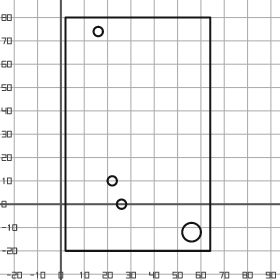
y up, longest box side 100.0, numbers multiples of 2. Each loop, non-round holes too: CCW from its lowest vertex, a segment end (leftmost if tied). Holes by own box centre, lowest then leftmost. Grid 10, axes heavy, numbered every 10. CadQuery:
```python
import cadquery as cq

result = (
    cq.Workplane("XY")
    .moveTo(2.0, -20.0)
    .lineTo(64.0, -20.0)
    .lineTo(64.0, 80.0)
    .lineTo(2.0, 80.0)
    .close()
    .moveTo(56.0, -12.0)
    .circle(4.0)
    .moveTo(26.0, 0.0)
    .circle(2.0)
    .moveTo(22.0, 10.0)
    .circle(2.0)
    .moveTo(16.0, 74.0)
    .circle(2.0)
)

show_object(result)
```